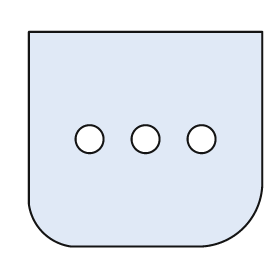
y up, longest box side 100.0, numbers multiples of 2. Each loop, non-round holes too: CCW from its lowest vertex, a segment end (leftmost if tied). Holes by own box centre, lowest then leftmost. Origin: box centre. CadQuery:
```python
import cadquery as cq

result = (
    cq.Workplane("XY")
    .moveTo(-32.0, -46.0)
    .lineTo(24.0, -46.0)
    .threePointArc((42.0, -38.0), (50.0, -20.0))
    .lineTo(50.0, 46.0)
    .lineTo(-50.0, 46.0)
    .lineTo(-50.0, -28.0)
    .threePointArc((-44.0, -40.0), (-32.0, -46.0))
    .close()
    .moveTo(-24.0, 0.0)
    .circle(6.0)
    .moveTo(0.0, 0.0)
    .circle(6.0)
    .moveTo(24.0, 0.0)
    .circle(6.0)
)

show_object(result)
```